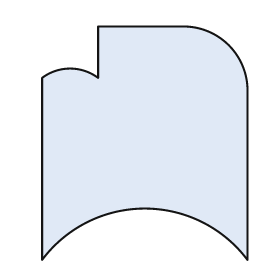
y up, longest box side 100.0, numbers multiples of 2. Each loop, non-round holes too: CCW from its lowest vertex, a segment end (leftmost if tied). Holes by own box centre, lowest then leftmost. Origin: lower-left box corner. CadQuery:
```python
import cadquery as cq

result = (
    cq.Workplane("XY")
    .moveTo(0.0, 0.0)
    .threePointArc((44.0, 22.0), (88.0, 0.0))
    .lineTo(88.0, 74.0)
    .threePointArc((80.0, 92.0), (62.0, 100.0))
    .lineTo(24.0, 100.0)
    .lineTo(24.0, 78.0)
    .threePointArc((12.0, 82.0), (0.0, 78.0))
    .close()
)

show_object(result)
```